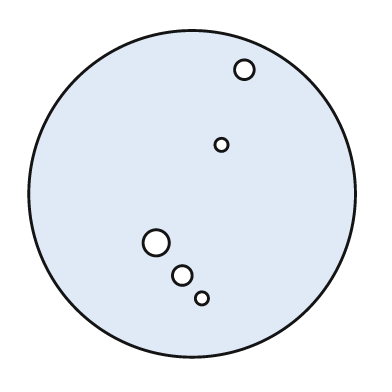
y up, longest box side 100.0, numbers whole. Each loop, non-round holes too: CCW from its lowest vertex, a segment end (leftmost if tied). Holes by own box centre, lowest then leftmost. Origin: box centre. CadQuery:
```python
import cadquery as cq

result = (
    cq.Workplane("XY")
    .moveTo(0.0, 0.0)
    .circle(50.0)
    .moveTo(3.0, -32.0)
    .circle(2.0)
    .moveTo(-3.0, -25.0)
    .circle(3.0)
    .moveTo(-11.0, -15.0)
    .circle(4.0)
    .moveTo(9.0, 15.0)
    .circle(2.0)
    .moveTo(16.0, 38.0)
    .circle(3.0)
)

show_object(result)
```